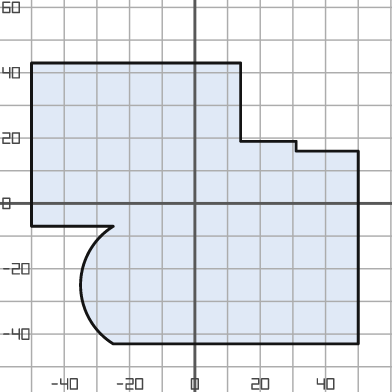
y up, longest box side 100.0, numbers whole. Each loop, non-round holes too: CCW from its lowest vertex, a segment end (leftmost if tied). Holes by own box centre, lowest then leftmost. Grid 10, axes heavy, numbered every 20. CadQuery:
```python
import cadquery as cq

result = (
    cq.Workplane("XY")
    .moveTo(-25.0, -43.0)
    .lineTo(50.0, -43.0)
    .lineTo(50.0, 16.0)
    .lineTo(31.0, 16.0)
    .lineTo(31.0, 19.0)
    .lineTo(14.0, 19.0)
    .lineTo(14.0, 43.0)
    .lineTo(-50.0, 43.0)
    .lineTo(-50.0, -7.0)
    .lineTo(-25.0, -7.0)
    .threePointArc((-35.0, -25.0), (-25.0, -43.0))
    .close()
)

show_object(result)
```